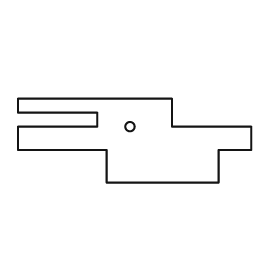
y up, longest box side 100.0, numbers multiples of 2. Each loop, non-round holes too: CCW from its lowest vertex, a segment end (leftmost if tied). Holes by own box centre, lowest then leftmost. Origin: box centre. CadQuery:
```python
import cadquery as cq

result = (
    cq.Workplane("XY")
    .moveTo(-12.0, -18.0)
    .lineTo(36.0, -18.0)
    .lineTo(36.0, -4.0)
    .lineTo(50.0, -4.0)
    .lineTo(50.0, 6.0)
    .lineTo(16.0, 6.0)
    .lineTo(16.0, 18.0)
    .lineTo(-50.0, 18.0)
    .lineTo(-50.0, 12.0)
    .lineTo(-16.0, 12.0)
    .lineTo(-16.0, 6.0)
    .lineTo(-50.0, 6.0)
    .lineTo(-50.0, -4.0)
    .lineTo(-12.0, -4.0)
    .close()
    .moveTo(-2.0, 6.0)
    .circle(2.0)
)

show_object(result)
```